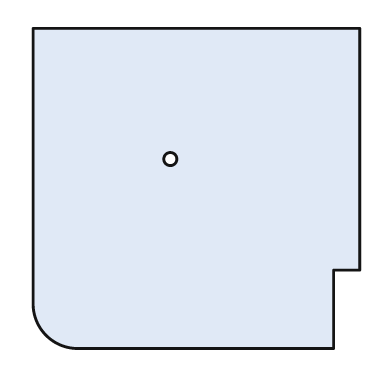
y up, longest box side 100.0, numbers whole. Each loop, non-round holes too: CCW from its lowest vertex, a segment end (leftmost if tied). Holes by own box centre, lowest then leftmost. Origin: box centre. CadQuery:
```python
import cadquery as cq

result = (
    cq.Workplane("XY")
    .moveTo(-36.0, -49.0)
    .lineTo(42.0, -49.0)
    .lineTo(42.0, -25.0)
    .lineTo(50.0, -25.0)
    .lineTo(50.0, 49.0)
    .lineTo(-50.0, 49.0)
    .lineTo(-50.0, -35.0)
    .threePointArc((-46.0, -45.0), (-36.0, -49.0))
    .close()
    .moveTo(-8.0, 9.0)
    .circle(2.0)
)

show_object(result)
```